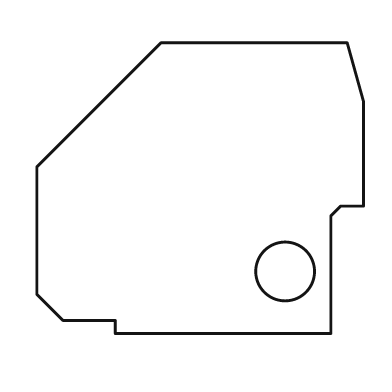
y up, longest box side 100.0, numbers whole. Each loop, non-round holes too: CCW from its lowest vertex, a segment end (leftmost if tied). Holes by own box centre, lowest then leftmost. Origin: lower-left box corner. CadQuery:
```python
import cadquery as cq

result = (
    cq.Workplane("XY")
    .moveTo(24.0, 0.0)
    .lineTo(90.0, 0.0)
    .lineTo(90.0, 36.0)
    .lineTo(93.0, 39.0)
    .lineTo(100.0, 39.0)
    .lineTo(100.0, 71.0)
    .lineTo(95.0, 89.0)
    .lineTo(38.0, 89.0)
    .lineTo(0.0, 51.0)
    .lineTo(0.0, 12.0)
    .lineTo(8.0, 4.0)
    .lineTo(24.0, 4.0)
    .close()
    .moveTo(76.0, 19.0)
    .circle(9.0)
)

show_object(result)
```